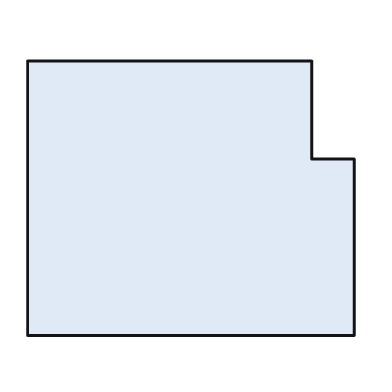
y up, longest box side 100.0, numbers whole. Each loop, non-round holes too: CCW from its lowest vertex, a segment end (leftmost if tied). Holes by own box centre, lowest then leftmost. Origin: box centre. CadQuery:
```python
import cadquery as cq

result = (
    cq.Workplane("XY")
    .moveTo(-50.0, -42.0)
    .lineTo(50.0, -42.0)
    .lineTo(50.0, 12.0)
    .lineTo(37.0, 12.0)
    .lineTo(37.0, 42.0)
    .lineTo(-50.0, 42.0)
    .close()
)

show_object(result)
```